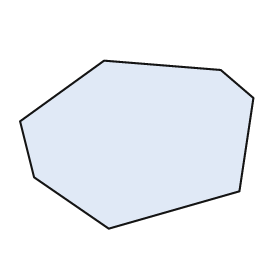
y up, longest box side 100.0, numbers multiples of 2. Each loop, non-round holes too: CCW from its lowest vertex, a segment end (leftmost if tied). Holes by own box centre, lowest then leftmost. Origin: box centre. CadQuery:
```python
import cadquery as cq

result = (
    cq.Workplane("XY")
    .moveTo(-12.0, -36.0)
    .lineTo(44.0, -20.0)
    .lineTo(50.0, 20.0)
    .lineTo(36.0, 32.0)
    .lineTo(-14.0, 36.0)
    .lineTo(-50.0, 10.0)
    .lineTo(-44.0, -14.0)
    .close()
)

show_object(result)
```